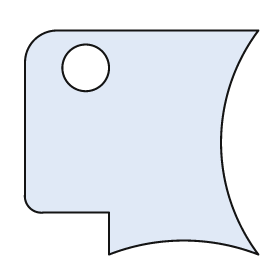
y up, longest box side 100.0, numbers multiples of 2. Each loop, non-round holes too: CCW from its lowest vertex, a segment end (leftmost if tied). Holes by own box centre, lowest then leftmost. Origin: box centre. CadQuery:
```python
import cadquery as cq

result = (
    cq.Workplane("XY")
    .moveTo(-14.0, -48.0)
    .threePointArc((18.0, -42.0), (50.0, -48.0))
    .threePointArc((34.0, 0.0), (50.0, 48.0))
    .lineTo(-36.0, 48.0)
    .threePointArc((-46.0, 44.0), (-50.0, 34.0))
    .lineTo(-50.0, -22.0)
    .threePointArc((-48.0, -28.0), (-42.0, -30.0))
    .lineTo(-14.0, -30.0)
    .close()
    .moveTo(-24.0, 32.0)
    .circle(10.0)
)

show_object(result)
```